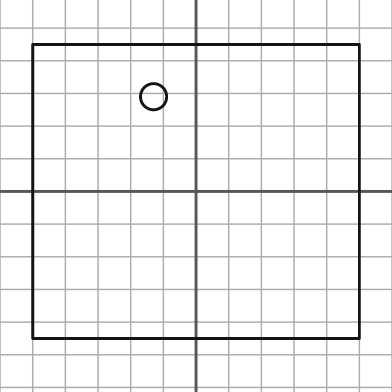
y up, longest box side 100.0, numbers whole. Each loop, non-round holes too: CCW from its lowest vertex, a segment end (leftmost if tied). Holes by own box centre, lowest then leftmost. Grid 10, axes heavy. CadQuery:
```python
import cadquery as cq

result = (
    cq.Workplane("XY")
    .moveTo(-50.0, -45.0)
    .lineTo(50.0, -45.0)
    .lineTo(50.0, 45.0)
    .lineTo(-50.0, 45.0)
    .close()
    .moveTo(-13.0, 29.0)
    .circle(4.0)
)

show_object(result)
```